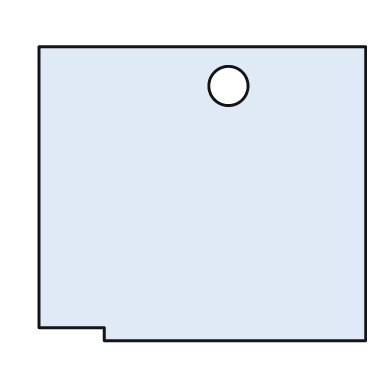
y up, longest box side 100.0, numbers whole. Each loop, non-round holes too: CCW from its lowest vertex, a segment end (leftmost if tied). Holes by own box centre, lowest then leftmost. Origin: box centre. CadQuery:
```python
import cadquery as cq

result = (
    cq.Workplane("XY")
    .moveTo(-30.0, -45.0)
    .lineTo(50.0, -45.0)
    .lineTo(50.0, 45.0)
    .lineTo(-50.0, 45.0)
    .lineTo(-50.0, -41.0)
    .lineTo(-30.0, -41.0)
    .close()
    .moveTo(8.0, 33.0)
    .circle(6.0)
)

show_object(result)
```